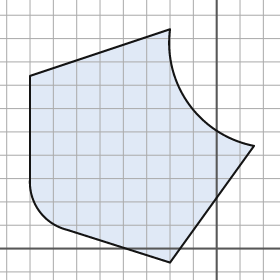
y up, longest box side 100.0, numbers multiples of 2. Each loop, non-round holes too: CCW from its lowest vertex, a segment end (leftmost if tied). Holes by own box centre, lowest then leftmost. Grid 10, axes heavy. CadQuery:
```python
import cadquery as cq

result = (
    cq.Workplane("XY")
    .moveTo(-20.0, -6.0)
    .lineTo(16.0, 44.0)
    .threePointArc((-12.0, 62.0), (-20.0, 94.0))
    .lineTo(-80.0, 74.0)
    .lineTo(-80.0, 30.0)
    .threePointArc((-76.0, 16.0), (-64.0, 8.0))
    .close()
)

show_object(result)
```